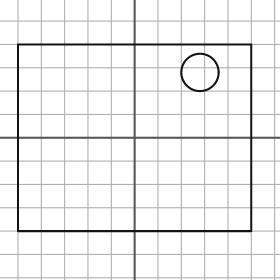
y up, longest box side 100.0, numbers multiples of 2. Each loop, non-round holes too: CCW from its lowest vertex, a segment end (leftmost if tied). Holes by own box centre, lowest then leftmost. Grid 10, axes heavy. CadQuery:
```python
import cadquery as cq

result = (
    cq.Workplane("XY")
    .moveTo(-50.0, -40.0)
    .lineTo(50.0, -40.0)
    .lineTo(50.0, 40.0)
    .lineTo(-50.0, 40.0)
    .close()
    .moveTo(28.0, 28.0)
    .circle(8.0)
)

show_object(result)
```